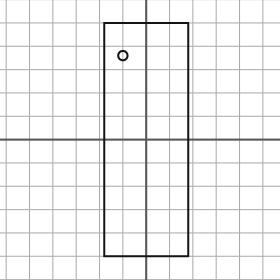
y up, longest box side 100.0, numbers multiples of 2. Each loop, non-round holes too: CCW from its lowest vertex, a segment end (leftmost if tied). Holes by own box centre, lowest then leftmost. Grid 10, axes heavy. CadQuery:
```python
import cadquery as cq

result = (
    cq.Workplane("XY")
    .moveTo(-18.0, -50.0)
    .lineTo(18.0, -50.0)
    .lineTo(18.0, 50.0)
    .lineTo(-18.0, 50.0)
    .close()
    .moveTo(-10.0, 36.0)
    .circle(2.0)
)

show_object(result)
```